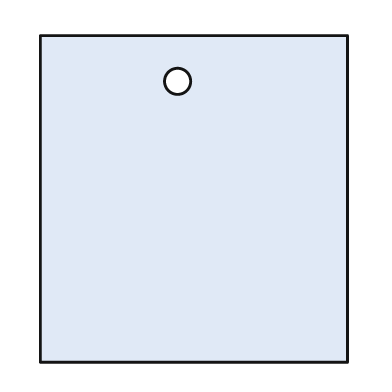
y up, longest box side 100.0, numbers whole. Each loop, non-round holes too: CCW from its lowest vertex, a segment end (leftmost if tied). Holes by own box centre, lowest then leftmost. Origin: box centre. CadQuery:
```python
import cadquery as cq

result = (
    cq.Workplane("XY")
    .moveTo(-47.0, -50.0)
    .lineTo(47.0, -50.0)
    .lineTo(47.0, 50.0)
    .lineTo(-47.0, 50.0)
    .close()
    .moveTo(-5.0, 36.0)
    .circle(4.0)
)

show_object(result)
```